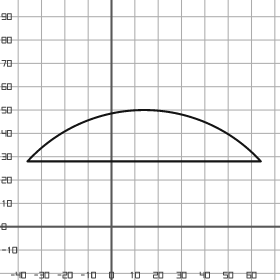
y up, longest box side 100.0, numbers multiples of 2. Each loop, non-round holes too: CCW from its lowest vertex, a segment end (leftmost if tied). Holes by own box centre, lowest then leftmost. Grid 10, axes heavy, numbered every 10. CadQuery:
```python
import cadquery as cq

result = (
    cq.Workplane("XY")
    .moveTo(-36.0, 28.0)
    .lineTo(64.0, 28.0)
    .threePointArc((14.0, 50.0), (-36.0, 28.0))
    .close()
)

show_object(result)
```